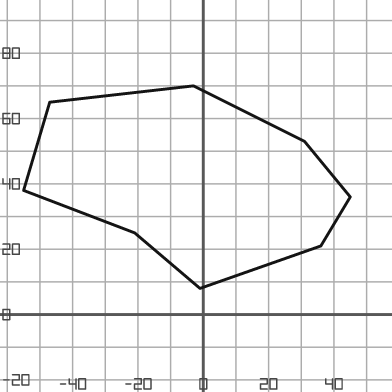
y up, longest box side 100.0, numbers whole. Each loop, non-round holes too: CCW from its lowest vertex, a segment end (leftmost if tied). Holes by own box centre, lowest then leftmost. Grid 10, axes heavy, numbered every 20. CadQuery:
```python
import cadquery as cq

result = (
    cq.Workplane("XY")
    .moveTo(-1.0, 8.0)
    .lineTo(36.0, 21.0)
    .lineTo(45.0, 36.0)
    .lineTo(31.0, 53.0)
    .lineTo(-3.0, 70.0)
    .lineTo(-47.0, 65.0)
    .lineTo(-55.0, 38.0)
    .lineTo(-21.0, 25.0)
    .close()
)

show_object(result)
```